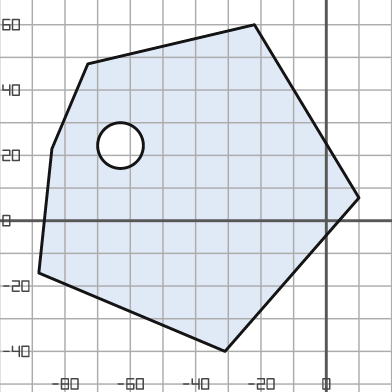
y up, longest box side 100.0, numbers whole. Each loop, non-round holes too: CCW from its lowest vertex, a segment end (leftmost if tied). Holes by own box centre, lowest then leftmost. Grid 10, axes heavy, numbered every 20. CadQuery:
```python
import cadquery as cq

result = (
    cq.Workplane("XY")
    .moveTo(-31.0, -40.0)
    .lineTo(10.0, 7.0)
    .lineTo(-22.0, 60.0)
    .lineTo(-73.0, 48.0)
    .lineTo(-84.0, 22.0)
    .lineTo(-88.0, -16.0)
    .close()
    .moveTo(-63.0, 23.0)
    .circle(7.0)
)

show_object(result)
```